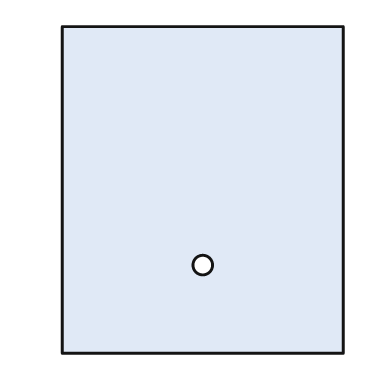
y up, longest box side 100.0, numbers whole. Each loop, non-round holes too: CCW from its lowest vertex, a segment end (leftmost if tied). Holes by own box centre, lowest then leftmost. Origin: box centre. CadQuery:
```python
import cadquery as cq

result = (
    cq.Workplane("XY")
    .moveTo(-43.0, -50.0)
    .lineTo(43.0, -50.0)
    .lineTo(43.0, 50.0)
    .lineTo(-43.0, 50.0)
    .close()
    .moveTo(0.0, -23.0)
    .circle(3.0)
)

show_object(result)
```